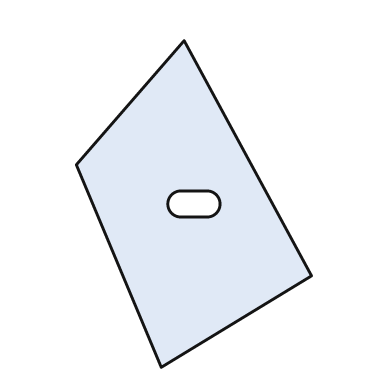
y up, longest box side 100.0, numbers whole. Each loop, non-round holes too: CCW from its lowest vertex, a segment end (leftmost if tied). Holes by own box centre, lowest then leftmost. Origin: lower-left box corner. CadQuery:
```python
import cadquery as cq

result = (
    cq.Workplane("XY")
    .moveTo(26.0, 0.0)
    .lineTo(72.0, 28.0)
    .lineTo(33.0, 100.0)
    .lineTo(0.0, 62.0)
    .close()
    .moveTo(32.0, 46.0)
    .lineTo(40.0, 46.0)
    .threePointArc((44.0, 50.0), (40.0, 54.0))
    .lineTo(32.0, 54.0)
    .threePointArc((28.0, 50.0), (32.0, 46.0))
    .close()
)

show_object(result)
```